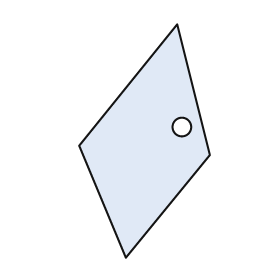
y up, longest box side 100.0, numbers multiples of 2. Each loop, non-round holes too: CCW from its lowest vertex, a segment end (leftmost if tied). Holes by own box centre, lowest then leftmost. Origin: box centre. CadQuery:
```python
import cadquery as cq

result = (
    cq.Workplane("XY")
    .moveTo(-8.0, -50.0)
    .lineTo(28.0, -6.0)
    .lineTo(14.0, 50.0)
    .lineTo(-28.0, -2.0)
    .close()
    .moveTo(16.0, 6.0)
    .circle(4.0)
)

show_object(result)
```